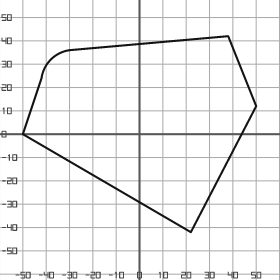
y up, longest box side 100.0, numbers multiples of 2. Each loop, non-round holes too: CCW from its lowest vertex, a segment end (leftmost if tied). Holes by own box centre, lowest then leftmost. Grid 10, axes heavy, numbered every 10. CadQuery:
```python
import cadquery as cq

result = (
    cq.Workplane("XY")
    .moveTo(22.0, -42.0)
    .lineTo(50.0, 12.0)
    .lineTo(38.0, 42.0)
    .lineTo(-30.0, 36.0)
    .threePointArc((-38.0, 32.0), (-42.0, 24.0))
    .lineTo(-50.0, 0.0)
    .close()
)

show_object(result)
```